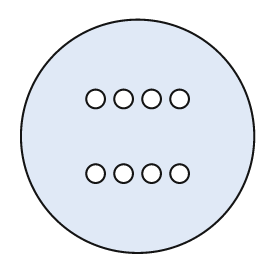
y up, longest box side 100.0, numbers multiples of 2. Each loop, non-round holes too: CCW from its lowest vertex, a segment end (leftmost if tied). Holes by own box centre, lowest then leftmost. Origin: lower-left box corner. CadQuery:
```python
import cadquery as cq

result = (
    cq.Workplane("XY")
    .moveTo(50.0, 50.0)
    .circle(50.0)
    .moveTo(32.0, 34.0)
    .circle(4.0)
    .moveTo(44.0, 34.0)
    .circle(4.0)
    .moveTo(56.0, 34.0)
    .circle(4.0)
    .moveTo(68.0, 34.0)
    .circle(4.0)
    .moveTo(32.0, 66.0)
    .circle(4.0)
    .moveTo(44.0, 66.0)
    .circle(4.0)
    .moveTo(56.0, 66.0)
    .circle(4.0)
    .moveTo(68.0, 66.0)
    .circle(4.0)
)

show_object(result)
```